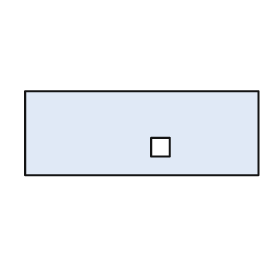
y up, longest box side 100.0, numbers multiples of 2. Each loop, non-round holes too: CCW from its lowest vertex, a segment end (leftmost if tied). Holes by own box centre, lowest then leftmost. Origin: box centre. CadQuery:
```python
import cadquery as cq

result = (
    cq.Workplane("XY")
    .moveTo(-50.0, -18.0)
    .lineTo(50.0, -18.0)
    .lineTo(50.0, 18.0)
    .lineTo(-50.0, 18.0)
    .close()
    .moveTo(4.0, -10.0)
    .lineTo(12.0, -10.0)
    .lineTo(12.0, -2.0)
    .lineTo(4.0, -2.0)
    .close()
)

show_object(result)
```